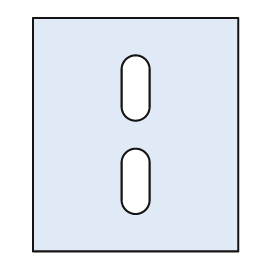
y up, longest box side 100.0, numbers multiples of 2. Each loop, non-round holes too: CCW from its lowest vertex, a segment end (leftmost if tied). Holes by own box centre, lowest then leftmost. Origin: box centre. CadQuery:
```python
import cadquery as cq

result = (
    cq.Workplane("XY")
    .moveTo(-44.0, -50.0)
    .lineTo(44.0, -50.0)
    .lineTo(44.0, 50.0)
    .lineTo(-44.0, 50.0)
    .close()
    .moveTo(-6.0, -28.0)
    .threePointArc((0.0, -34.0), (6.0, -28.0))
    .lineTo(6.0, -12.0)
    .threePointArc((0.0, -6.0), (-6.0, -12.0))
    .close()
    .moveTo(-6.0, 12.0)
    .threePointArc((0.0, 6.0), (6.0, 12.0))
    .lineTo(6.0, 28.0)
    .threePointArc((0.0, 34.0), (-6.0, 28.0))
    .close()
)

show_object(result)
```